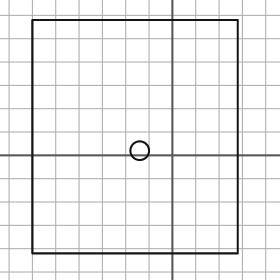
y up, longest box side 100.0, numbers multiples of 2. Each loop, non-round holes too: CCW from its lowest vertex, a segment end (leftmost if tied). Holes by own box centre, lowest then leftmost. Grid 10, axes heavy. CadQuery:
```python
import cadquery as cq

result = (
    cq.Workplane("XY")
    .moveTo(-60.0, -42.0)
    .lineTo(28.0, -42.0)
    .lineTo(28.0, 58.0)
    .lineTo(-60.0, 58.0)
    .close()
    .moveTo(-14.0, 2.0)
    .circle(4.0)
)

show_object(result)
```